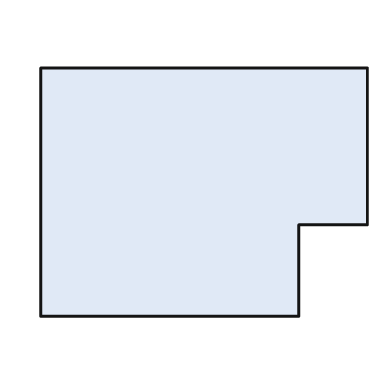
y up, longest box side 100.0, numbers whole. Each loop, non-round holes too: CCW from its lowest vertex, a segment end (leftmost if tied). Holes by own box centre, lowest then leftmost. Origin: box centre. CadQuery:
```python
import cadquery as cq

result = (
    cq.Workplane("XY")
    .moveTo(-50.0, -38.0)
    .lineTo(29.0, -38.0)
    .lineTo(29.0, -10.0)
    .lineTo(50.0, -10.0)
    .lineTo(50.0, 38.0)
    .lineTo(-50.0, 38.0)
    .close()
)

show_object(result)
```